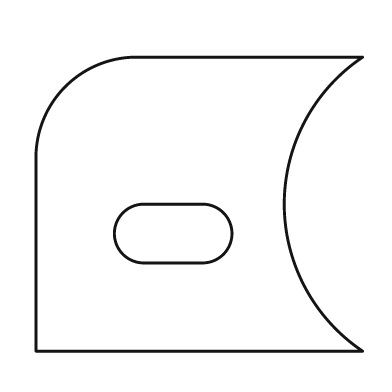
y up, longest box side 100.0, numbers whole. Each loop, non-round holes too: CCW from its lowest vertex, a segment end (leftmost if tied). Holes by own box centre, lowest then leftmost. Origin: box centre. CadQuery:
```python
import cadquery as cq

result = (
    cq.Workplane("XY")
    .moveTo(-50.0, -45.0)
    .lineTo(50.0, -45.0)
    .threePointArc((26.0, 0.0), (50.0, 45.0))
    .lineTo(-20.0, 45.0)
    .threePointArc((-41.0, 36.0), (-50.0, 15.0))
    .close()
    .moveTo(-17.0, -18.0)
    .lineTo(1.0, -18.0)
    .threePointArc((10.0, -9.0), (1.0, 0.0))
    .lineTo(-17.0, 0.0)
    .threePointArc((-26.0, -9.0), (-17.0, -18.0))
    .close()
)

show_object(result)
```